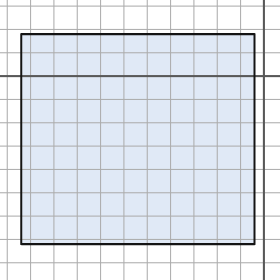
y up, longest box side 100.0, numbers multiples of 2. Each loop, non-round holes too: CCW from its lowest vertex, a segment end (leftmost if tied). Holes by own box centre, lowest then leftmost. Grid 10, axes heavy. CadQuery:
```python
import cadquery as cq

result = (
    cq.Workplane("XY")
    .moveTo(-104.0, -72.0)
    .lineTo(-4.0, -72.0)
    .lineTo(-4.0, 18.0)
    .lineTo(-104.0, 18.0)
    .close()
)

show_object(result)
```